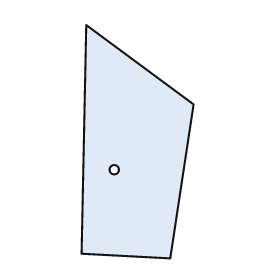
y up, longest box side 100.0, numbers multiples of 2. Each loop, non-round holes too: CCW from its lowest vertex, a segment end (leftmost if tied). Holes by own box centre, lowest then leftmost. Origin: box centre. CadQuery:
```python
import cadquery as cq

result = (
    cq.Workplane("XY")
    .moveTo(14.0, -50.0)
    .lineTo(24.0, 16.0)
    .lineTo(-22.0, 50.0)
    .lineTo(-24.0, -48.0)
    .close()
    .moveTo(-10.0, -12.0)
    .circle(2.0)
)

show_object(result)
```